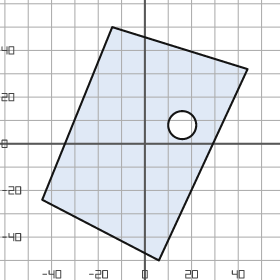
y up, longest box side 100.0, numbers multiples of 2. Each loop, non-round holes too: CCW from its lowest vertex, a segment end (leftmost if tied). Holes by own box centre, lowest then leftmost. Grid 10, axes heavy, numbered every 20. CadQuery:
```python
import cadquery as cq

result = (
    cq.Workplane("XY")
    .moveTo(6.0, -50.0)
    .lineTo(44.0, 32.0)
    .lineTo(-14.0, 50.0)
    .lineTo(-44.0, -24.0)
    .close()
    .moveTo(16.0, 8.0)
    .circle(6.0)
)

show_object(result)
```